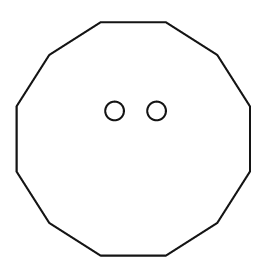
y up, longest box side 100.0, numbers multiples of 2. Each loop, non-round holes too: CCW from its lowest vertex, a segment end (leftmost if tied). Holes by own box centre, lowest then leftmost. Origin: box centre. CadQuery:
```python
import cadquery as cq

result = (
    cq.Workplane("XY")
    .moveTo(-14.0, -50.0)
    .lineTo(14.0, -50.0)
    .lineTo(36.0, -36.0)
    .lineTo(50.0, -14.0)
    .lineTo(50.0, 14.0)
    .lineTo(36.0, 36.0)
    .lineTo(14.0, 50.0)
    .lineTo(-14.0, 50.0)
    .lineTo(-36.0, 36.0)
    .lineTo(-50.0, 14.0)
    .lineTo(-50.0, -14.0)
    .lineTo(-36.0, -36.0)
    .close()
    .moveTo(-8.0, 12.0)
    .circle(4.0)
    .moveTo(10.0, 12.0)
    .circle(4.0)
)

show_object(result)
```